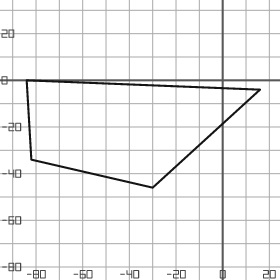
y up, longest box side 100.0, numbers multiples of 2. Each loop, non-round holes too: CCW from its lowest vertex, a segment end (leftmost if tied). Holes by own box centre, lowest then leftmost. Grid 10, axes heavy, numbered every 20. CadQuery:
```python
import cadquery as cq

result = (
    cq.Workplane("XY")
    .moveTo(-30.0, -46.0)
    .lineTo(16.0, -4.0)
    .lineTo(-84.0, 0.0)
    .lineTo(-82.0, -34.0)
    .close()
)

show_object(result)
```